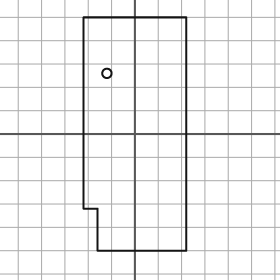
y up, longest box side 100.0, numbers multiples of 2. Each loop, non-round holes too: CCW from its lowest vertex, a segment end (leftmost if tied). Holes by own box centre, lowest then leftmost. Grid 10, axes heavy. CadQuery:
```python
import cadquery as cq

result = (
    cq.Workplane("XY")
    .moveTo(-16.0, -50.0)
    .lineTo(22.0, -50.0)
    .lineTo(22.0, 50.0)
    .lineTo(-22.0, 50.0)
    .lineTo(-22.0, -32.0)
    .lineTo(-16.0, -32.0)
    .close()
    .moveTo(-12.0, 26.0)
    .circle(2.0)
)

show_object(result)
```